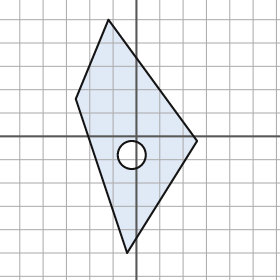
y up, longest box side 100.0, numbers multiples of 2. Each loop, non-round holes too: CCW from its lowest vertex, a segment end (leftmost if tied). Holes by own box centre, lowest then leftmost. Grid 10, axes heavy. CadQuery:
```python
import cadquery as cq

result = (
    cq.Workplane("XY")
    .moveTo(-4.0, -50.0)
    .lineTo(26.0, -2.0)
    .lineTo(-12.0, 50.0)
    .lineTo(-26.0, 16.0)
    .close()
    .moveTo(-2.0, -8.0)
    .circle(6.0)
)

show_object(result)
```